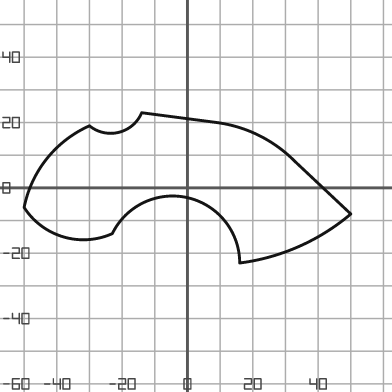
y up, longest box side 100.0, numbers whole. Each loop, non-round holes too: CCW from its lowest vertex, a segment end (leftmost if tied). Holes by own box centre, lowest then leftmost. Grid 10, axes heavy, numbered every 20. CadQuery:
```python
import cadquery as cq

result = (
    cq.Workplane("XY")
    .moveTo(16.0, -23.0)
    .threePointArc((34.0, -18.0), (50.0, -8.0))
    .lineTo(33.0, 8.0)
    .threePointArc((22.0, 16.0), (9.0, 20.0))
    .lineTo(-14.0, 23.0)
    .threePointArc((-21.0, 17.0), (-30.0, 19.0))
    .threePointArc((-43.0, 9.0), (-50.0, -6.0))
    .threePointArc((-38.0, -15.0), (-23.0, -14.0))
    .threePointArc((0.0, -3.0), (16.0, -23.0))
    .close()
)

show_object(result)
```